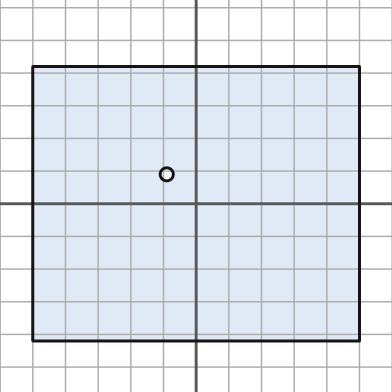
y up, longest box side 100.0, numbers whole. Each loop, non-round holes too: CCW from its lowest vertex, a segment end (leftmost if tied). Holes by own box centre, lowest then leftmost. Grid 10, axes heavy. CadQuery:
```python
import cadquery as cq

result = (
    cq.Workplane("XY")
    .moveTo(-50.0, -42.0)
    .lineTo(50.0, -42.0)
    .lineTo(50.0, 42.0)
    .lineTo(-50.0, 42.0)
    .close()
    .moveTo(-9.0, 9.0)
    .circle(2.0)
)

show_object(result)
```